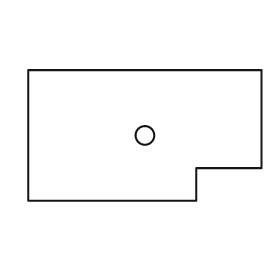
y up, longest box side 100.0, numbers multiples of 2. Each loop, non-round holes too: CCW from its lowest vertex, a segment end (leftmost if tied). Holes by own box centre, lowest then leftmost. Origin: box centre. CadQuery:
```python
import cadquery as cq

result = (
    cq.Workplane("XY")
    .moveTo(-50.0, -28.0)
    .lineTo(22.0, -28.0)
    .lineTo(22.0, -14.0)
    .lineTo(50.0, -14.0)
    .lineTo(50.0, 28.0)
    .lineTo(-50.0, 28.0)
    .close()
    .moveTo(0.0, 0.0)
    .circle(4.0)
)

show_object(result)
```